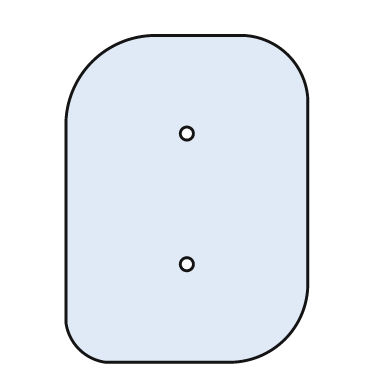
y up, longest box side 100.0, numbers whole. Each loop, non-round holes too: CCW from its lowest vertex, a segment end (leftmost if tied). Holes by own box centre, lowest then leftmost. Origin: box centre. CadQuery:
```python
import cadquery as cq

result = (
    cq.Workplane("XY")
    .moveTo(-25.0, -50.0)
    .lineTo(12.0, -50.0)
    .threePointArc((30.0, -43.0), (37.0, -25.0))
    .lineTo(37.0, 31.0)
    .threePointArc((31.0, 44.0), (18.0, 50.0))
    .lineTo(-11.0, 50.0)
    .threePointArc((-29.0, 42.0), (-37.0, 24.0))
    .lineTo(-37.0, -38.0)
    .threePointArc((-33.0, -46.0), (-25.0, -50.0))
    .close()
    .moveTo(0.0, -20.0)
    .circle(2.0)
    .moveTo(0.0, 20.0)
    .circle(2.0)
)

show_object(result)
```